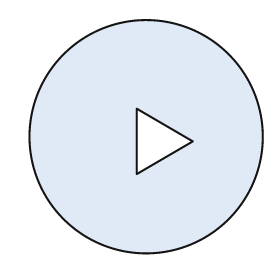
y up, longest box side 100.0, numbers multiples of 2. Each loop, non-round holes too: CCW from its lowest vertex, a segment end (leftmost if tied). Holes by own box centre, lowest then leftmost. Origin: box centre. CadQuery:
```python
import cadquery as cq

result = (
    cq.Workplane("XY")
    .moveTo(0.0, 0.0)
    .circle(50.0)
    .moveTo(-4.0, -16.0)
    .lineTo(20.0, -2.0)
    .lineTo(-4.0, 12.0)
    .close()
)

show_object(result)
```